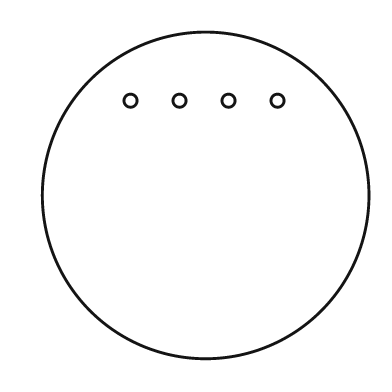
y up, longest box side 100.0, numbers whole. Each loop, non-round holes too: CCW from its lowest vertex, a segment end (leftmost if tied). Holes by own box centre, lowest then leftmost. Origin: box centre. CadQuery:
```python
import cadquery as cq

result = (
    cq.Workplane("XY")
    .moveTo(0.0, 0.0)
    .circle(50.0)
    .moveTo(-23.0, 29.0)
    .circle(2.0)
    .moveTo(-8.0, 29.0)
    .circle(2.0)
    .moveTo(7.0, 29.0)
    .circle(2.0)
    .moveTo(22.0, 29.0)
    .circle(2.0)
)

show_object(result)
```